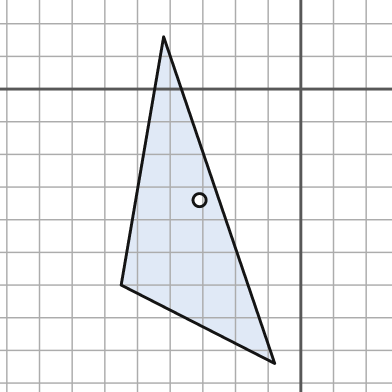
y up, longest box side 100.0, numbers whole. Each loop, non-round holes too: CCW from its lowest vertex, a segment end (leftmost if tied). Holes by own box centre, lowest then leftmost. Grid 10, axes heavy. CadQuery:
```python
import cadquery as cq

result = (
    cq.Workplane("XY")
    .moveTo(-8.0, -84.0)
    .lineTo(-42.0, 16.0)
    .lineTo(-55.0, -60.0)
    .close()
    .moveTo(-31.0, -34.0)
    .circle(2.0)
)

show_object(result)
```